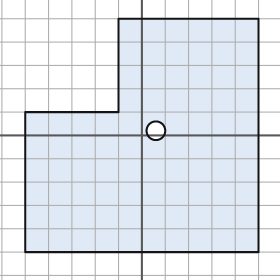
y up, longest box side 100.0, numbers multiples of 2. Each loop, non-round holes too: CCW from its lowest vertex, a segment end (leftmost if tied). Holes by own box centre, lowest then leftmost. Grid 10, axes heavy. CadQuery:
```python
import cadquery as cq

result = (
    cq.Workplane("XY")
    .moveTo(-50.0, -50.0)
    .lineTo(50.0, -50.0)
    .lineTo(50.0, 50.0)
    .lineTo(-10.0, 50.0)
    .lineTo(-10.0, 10.0)
    .lineTo(-50.0, 10.0)
    .close()
    .moveTo(6.0, 2.0)
    .circle(4.0)
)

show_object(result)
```